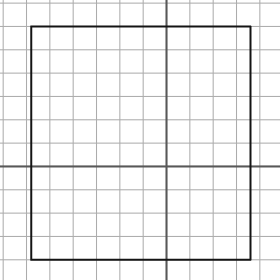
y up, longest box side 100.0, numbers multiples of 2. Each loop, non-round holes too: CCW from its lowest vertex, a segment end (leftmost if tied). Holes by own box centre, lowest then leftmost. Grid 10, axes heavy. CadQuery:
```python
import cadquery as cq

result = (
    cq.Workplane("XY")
    .moveTo(-58.0, -40.0)
    .lineTo(36.0, -40.0)
    .lineTo(36.0, 60.0)
    .lineTo(-58.0, 60.0)
    .close()
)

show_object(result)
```